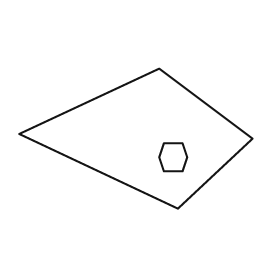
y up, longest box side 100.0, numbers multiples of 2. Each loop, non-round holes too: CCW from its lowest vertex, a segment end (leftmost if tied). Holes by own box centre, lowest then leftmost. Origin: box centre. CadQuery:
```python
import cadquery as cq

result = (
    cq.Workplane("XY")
    .moveTo(18.0, -30.0)
    .lineTo(50.0, 0.0)
    .lineTo(10.0, 30.0)
    .lineTo(-50.0, 2.0)
    .close()
    .moveTo(12.0, -14.0)
    .lineTo(20.0, -14.0)
    .lineTo(22.0, -8.0)
    .lineTo(20.0, -2.0)
    .lineTo(12.0, -2.0)
    .lineTo(10.0, -8.0)
    .close()
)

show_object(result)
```